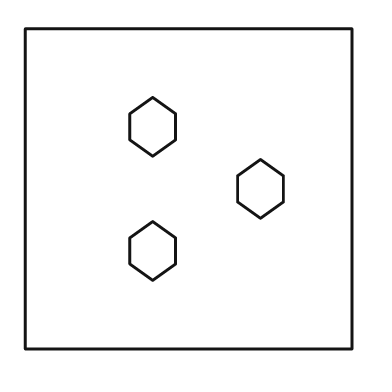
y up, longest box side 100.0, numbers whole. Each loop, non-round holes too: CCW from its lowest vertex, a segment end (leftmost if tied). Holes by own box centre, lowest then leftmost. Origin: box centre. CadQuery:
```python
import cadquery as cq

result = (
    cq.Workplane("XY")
    .moveTo(-50.0, -49.0)
    .lineTo(50.0, -49.0)
    .lineTo(50.0, 49.0)
    .lineTo(-50.0, 49.0)
    .close()
    .moveTo(-11.0, -28.0)
    .lineTo(-4.0, -23.0)
    .lineTo(-4.0, -15.0)
    .lineTo(-11.0, -10.0)
    .lineTo(-18.0, -15.0)
    .lineTo(-18.0, -23.0)
    .close()
    .moveTo(22.0, -9.0)
    .lineTo(29.0, -4.0)
    .lineTo(29.0, 4.0)
    .lineTo(22.0, 9.0)
    .lineTo(15.0, 4.0)
    .lineTo(15.0, -4.0)
    .close()
    .moveTo(-11.0, 10.0)
    .lineTo(-4.0, 15.0)
    .lineTo(-4.0, 23.0)
    .lineTo(-11.0, 28.0)
    .lineTo(-18.0, 23.0)
    .lineTo(-18.0, 15.0)
    .close()
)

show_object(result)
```